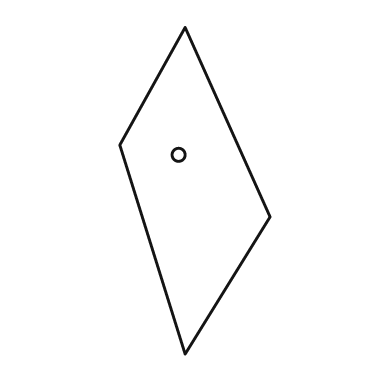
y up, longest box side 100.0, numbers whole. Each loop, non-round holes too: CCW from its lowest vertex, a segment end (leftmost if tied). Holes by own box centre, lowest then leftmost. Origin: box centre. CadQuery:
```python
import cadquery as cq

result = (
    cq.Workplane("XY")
    .moveTo(-3.0, -50.0)
    .lineTo(23.0, -8.0)
    .lineTo(-3.0, 50.0)
    .lineTo(-23.0, 14.0)
    .close()
    .moveTo(-5.0, 11.0)
    .circle(2.0)
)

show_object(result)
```